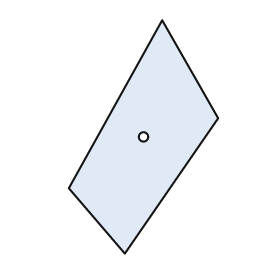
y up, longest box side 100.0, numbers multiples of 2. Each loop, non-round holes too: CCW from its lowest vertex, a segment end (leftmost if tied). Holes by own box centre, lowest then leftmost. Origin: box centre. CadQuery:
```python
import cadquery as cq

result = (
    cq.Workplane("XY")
    .moveTo(-8.0, -50.0)
    .lineTo(32.0, 8.0)
    .lineTo(8.0, 50.0)
    .lineTo(-32.0, -22.0)
    .close()
    .moveTo(0.0, 0.0)
    .circle(2.0)
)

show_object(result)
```